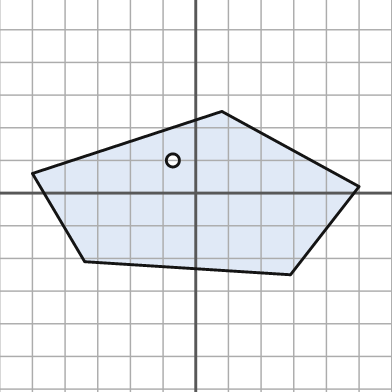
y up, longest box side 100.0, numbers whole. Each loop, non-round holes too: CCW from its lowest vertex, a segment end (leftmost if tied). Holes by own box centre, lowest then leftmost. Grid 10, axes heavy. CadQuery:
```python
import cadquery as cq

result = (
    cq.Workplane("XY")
    .moveTo(29.0, -25.0)
    .lineTo(50.0, 2.0)
    .lineTo(8.0, 25.0)
    .lineTo(-50.0, 6.0)
    .lineTo(-34.0, -21.0)
    .close()
    .moveTo(-7.0, 10.0)
    .circle(2.0)
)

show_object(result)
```